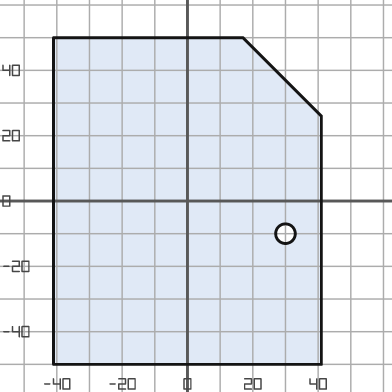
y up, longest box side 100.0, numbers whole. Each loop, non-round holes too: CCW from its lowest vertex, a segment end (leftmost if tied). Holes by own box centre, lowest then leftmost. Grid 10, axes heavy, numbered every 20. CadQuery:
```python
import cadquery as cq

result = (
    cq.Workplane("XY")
    .moveTo(-41.0, -50.0)
    .lineTo(41.0, -50.0)
    .lineTo(41.0, 26.0)
    .lineTo(17.0, 50.0)
    .lineTo(-41.0, 50.0)
    .close()
    .moveTo(30.0, -10.0)
    .circle(3.0)
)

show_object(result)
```